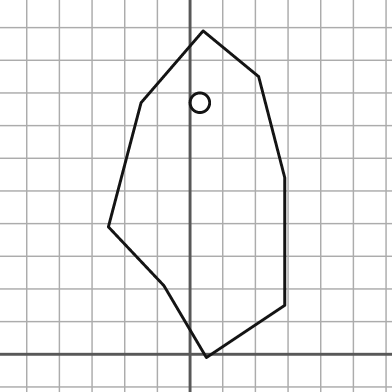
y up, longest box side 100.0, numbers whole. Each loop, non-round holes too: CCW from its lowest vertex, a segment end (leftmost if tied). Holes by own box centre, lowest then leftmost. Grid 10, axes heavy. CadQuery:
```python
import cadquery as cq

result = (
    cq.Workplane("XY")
    .moveTo(5.0, -1.0)
    .lineTo(29.0, 15.0)
    .lineTo(29.0, 54.0)
    .lineTo(21.0, 85.0)
    .lineTo(4.0, 99.0)
    .lineTo(-15.0, 77.0)
    .lineTo(-25.0, 39.0)
    .lineTo(-8.0, 21.0)
    .close()
    .moveTo(3.0, 77.0)
    .circle(3.0)
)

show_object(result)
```